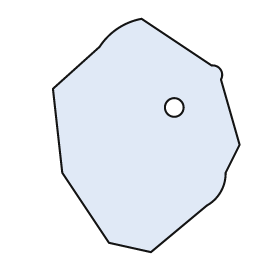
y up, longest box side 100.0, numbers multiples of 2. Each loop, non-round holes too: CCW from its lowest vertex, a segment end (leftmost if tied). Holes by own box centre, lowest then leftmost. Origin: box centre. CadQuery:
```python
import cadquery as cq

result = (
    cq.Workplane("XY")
    .moveTo(2.0, -50.0)
    .lineTo(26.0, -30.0)
    .threePointArc((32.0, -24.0), (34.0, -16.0))
    .lineTo(40.0, -4.0)
    .lineTo(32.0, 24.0)
    .threePointArc((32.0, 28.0), (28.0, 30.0))
    .lineTo(-2.0, 50.0)
    .threePointArc((-12.0, 46.0), (-20.0, 38.0))
    .lineTo(-40.0, 20.0)
    .lineTo(-36.0, -16.0)
    .lineTo(-16.0, -46.0)
    .close()
    .moveTo(12.0, 12.0)
    .circle(4.0)
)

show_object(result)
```